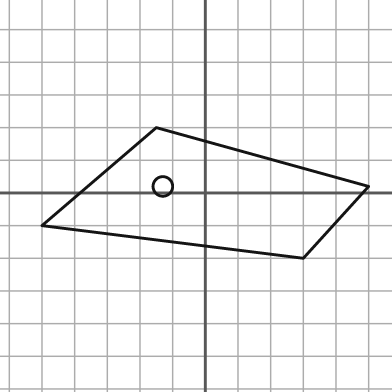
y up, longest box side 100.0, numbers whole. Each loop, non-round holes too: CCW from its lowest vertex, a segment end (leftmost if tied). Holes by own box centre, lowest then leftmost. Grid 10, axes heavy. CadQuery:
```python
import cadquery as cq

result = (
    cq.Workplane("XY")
    .moveTo(30.0, -20.0)
    .lineTo(50.0, 2.0)
    .lineTo(-15.0, 20.0)
    .lineTo(-50.0, -10.0)
    .close()
    .moveTo(-13.0, 2.0)
    .circle(3.0)
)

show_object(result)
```